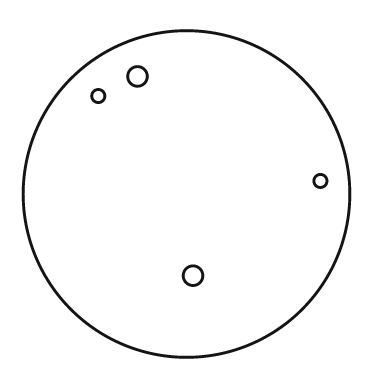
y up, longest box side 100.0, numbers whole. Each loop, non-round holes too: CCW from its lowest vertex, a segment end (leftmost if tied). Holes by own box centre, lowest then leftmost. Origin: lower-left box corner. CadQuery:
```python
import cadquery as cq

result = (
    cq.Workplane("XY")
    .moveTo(50.0, 50.0)
    .circle(50.0)
    .moveTo(52.0, 25.0)
    .circle(3.0)
    .moveTo(91.0, 54.0)
    .circle(2.0)
    .moveTo(23.0, 80.0)
    .circle(2.0)
    .moveTo(35.0, 86.0)
    .circle(3.0)
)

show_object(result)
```